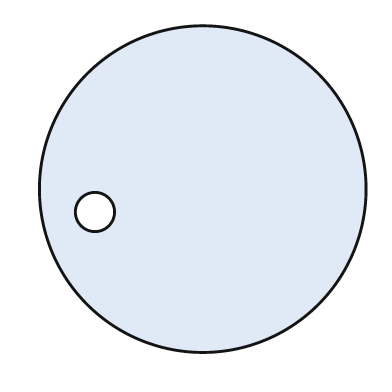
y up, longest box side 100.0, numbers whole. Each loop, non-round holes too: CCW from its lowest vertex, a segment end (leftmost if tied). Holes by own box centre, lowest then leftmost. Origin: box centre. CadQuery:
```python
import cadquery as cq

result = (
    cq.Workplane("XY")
    .moveTo(0.0, 0.0)
    .circle(50.0)
    .moveTo(-33.0, -7.0)
    .circle(6.0)
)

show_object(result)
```